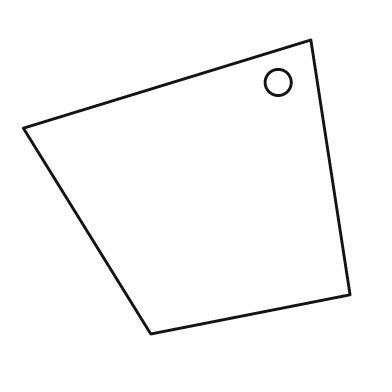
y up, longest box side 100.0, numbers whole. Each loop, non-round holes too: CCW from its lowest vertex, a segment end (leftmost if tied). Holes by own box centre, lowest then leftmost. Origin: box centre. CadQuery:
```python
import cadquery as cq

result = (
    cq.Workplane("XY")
    .moveTo(-11.0, -45.0)
    .lineTo(50.0, -33.0)
    .lineTo(38.0, 45.0)
    .lineTo(-50.0, 18.0)
    .close()
    .moveTo(28.0, 32.0)
    .circle(4.0)
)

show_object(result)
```